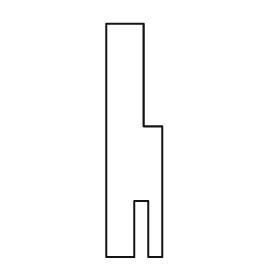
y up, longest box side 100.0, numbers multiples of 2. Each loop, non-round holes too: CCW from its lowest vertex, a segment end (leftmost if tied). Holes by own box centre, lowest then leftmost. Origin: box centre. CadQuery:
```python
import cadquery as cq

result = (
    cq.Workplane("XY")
    .moveTo(-12.0, -50.0)
    .lineTo(0.0, -50.0)
    .lineTo(0.0, -26.0)
    .lineTo(6.0, -26.0)
    .lineTo(6.0, -50.0)
    .lineTo(12.0, -50.0)
    .lineTo(12.0, 6.0)
    .lineTo(4.0, 6.0)
    .lineTo(4.0, 50.0)
    .lineTo(-12.0, 50.0)
    .close()
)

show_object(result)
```